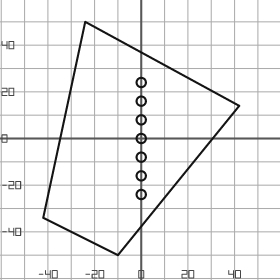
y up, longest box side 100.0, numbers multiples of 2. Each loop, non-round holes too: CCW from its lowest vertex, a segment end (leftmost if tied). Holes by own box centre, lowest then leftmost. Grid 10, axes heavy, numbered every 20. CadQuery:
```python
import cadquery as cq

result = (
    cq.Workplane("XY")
    .moveTo(-10.0, -50.0)
    .lineTo(42.0, 14.0)
    .lineTo(-24.0, 50.0)
    .lineTo(-42.0, -34.0)
    .close()
    .moveTo(0.0, -24.0)
    .circle(2.0)
    .moveTo(0.0, -16.0)
    .circle(2.0)
    .moveTo(0.0, -8.0)
    .circle(2.0)
    .moveTo(0.0, 0.0)
    .circle(2.0)
    .moveTo(0.0, 8.0)
    .circle(2.0)
    .moveTo(0.0, 16.0)
    .circle(2.0)
    .moveTo(0.0, 24.0)
    .circle(2.0)
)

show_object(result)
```